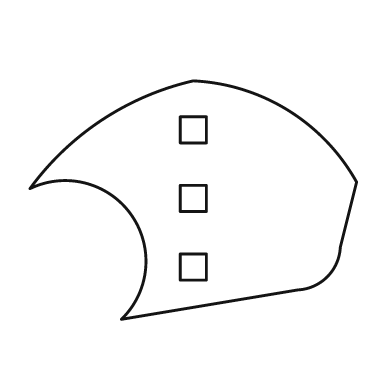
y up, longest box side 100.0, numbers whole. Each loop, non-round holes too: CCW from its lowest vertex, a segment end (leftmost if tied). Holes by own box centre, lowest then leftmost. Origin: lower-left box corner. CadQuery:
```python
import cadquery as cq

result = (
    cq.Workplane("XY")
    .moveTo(28.0, 0.0)
    .lineTo(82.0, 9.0)
    .threePointArc((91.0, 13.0), (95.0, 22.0))
    .lineTo(100.0, 42.0)
    .threePointArc((79.0, 64.0), (50.0, 73.0))
    .threePointArc((22.0, 61.0), (0.0, 40.0))
    .threePointArc((31.0, 32.0), (28.0, 0.0))
    .close()
    .moveTo(46.0, 12.0)
    .lineTo(54.0, 12.0)
    .lineTo(54.0, 20.0)
    .lineTo(46.0, 20.0)
    .close()
    .moveTo(46.0, 33.0)
    .lineTo(54.0, 33.0)
    .lineTo(54.0, 41.0)
    .lineTo(46.0, 41.0)
    .close()
    .moveTo(46.0, 54.0)
    .lineTo(54.0, 54.0)
    .lineTo(54.0, 62.0)
    .lineTo(46.0, 62.0)
    .close()
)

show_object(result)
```